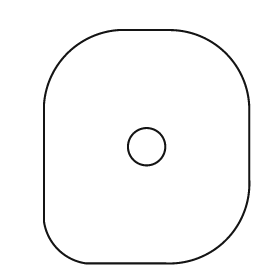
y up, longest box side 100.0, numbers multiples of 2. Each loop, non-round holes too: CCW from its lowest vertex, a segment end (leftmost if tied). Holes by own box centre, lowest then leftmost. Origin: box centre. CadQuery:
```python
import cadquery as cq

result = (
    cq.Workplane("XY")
    .moveTo(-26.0, -50.0)
    .lineTo(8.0, -50.0)
    .threePointArc((34.0, -40.0), (44.0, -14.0))
    .lineTo(44.0, 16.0)
    .threePointArc((34.0, 40.0), (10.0, 50.0))
    .lineTo(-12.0, 50.0)
    .threePointArc((-34.0, 40.0), (-44.0, 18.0))
    .lineTo(-44.0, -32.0)
    .threePointArc((-38.0, -44.0), (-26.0, -50.0))
    .close()
    .moveTo(0.0, 0.0)
    .circle(8.0)
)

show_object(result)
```